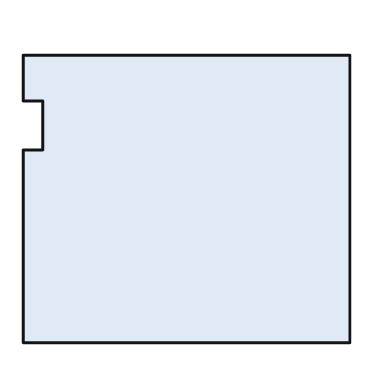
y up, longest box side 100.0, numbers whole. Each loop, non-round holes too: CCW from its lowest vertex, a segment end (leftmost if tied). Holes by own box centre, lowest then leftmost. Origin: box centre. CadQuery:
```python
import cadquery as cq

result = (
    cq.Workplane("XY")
    .moveTo(-50.0, -44.0)
    .lineTo(50.0, -44.0)
    .lineTo(50.0, 44.0)
    .lineTo(-50.0, 44.0)
    .lineTo(-50.0, 30.0)
    .lineTo(-44.0, 30.0)
    .lineTo(-44.0, 15.0)
    .lineTo(-50.0, 15.0)
    .close()
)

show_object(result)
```